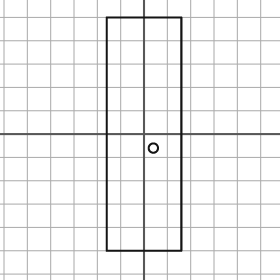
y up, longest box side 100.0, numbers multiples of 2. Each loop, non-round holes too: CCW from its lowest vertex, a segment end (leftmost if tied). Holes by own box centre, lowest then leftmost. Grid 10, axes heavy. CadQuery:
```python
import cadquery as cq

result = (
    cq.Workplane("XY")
    .moveTo(-16.0, -50.0)
    .lineTo(16.0, -50.0)
    .lineTo(16.0, 50.0)
    .lineTo(-16.0, 50.0)
    .close()
    .moveTo(4.0, -6.0)
    .circle(2.0)
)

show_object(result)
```